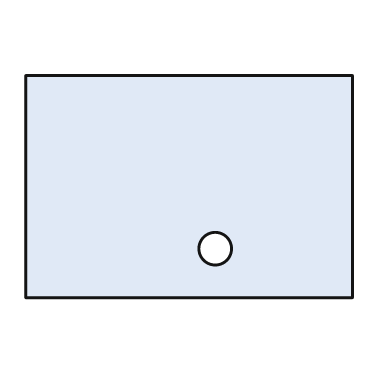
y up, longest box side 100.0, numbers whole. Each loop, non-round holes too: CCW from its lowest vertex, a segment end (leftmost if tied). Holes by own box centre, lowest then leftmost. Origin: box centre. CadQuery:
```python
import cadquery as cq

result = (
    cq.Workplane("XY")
    .moveTo(-50.0, -34.0)
    .lineTo(50.0, -34.0)
    .lineTo(50.0, 34.0)
    .lineTo(-50.0, 34.0)
    .close()
    .moveTo(8.0, -19.0)
    .circle(5.0)
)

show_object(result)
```